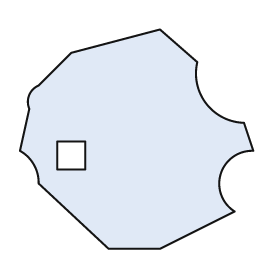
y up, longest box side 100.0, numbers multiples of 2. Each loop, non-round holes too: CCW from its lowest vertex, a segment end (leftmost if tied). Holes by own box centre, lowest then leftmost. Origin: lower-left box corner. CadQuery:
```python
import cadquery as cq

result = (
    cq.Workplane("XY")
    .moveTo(38.0, 0.0)
    .lineTo(60.0, 0.0)
    .lineTo(92.0, 16.0)
    .threePointArc((86.0, 32.0), (100.0, 42.0))
    .lineTo(96.0, 54.0)
    .threePointArc((80.0, 62.0), (76.0, 80.0))
    .lineTo(60.0, 94.0)
    .lineTo(22.0, 84.0)
    .lineTo(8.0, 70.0)
    .threePointArc((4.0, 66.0), (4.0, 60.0))
    .lineTo(0.0, 42.0)
    .threePointArc((6.0, 36.0), (8.0, 28.0))
    .close()
    .moveTo(16.0, 34.0)
    .lineTo(28.0, 34.0)
    .lineTo(28.0, 46.0)
    .lineTo(16.0, 46.0)
    .close()
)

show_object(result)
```